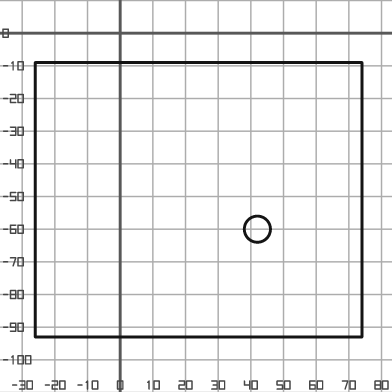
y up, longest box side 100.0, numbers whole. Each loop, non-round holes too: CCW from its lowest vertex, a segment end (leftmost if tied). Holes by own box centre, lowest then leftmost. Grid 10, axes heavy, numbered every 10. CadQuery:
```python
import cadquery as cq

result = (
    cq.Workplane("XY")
    .moveTo(-26.0, -93.0)
    .lineTo(74.0, -93.0)
    .lineTo(74.0, -9.0)
    .lineTo(-26.0, -9.0)
    .close()
    .moveTo(42.0, -60.0)
    .circle(4.0)
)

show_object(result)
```